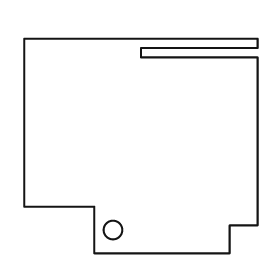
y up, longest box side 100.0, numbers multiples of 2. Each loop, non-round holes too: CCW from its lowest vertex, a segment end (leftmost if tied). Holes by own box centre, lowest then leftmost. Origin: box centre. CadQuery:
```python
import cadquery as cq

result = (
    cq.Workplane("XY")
    .moveTo(-20.0, -46.0)
    .lineTo(38.0, -46.0)
    .lineTo(38.0, -34.0)
    .lineTo(50.0, -34.0)
    .lineTo(50.0, 38.0)
    .lineTo(0.0, 38.0)
    .lineTo(0.0, 42.0)
    .lineTo(50.0, 42.0)
    .lineTo(50.0, 46.0)
    .lineTo(-50.0, 46.0)
    .lineTo(-50.0, -26.0)
    .lineTo(-20.0, -26.0)
    .close()
    .moveTo(-12.0, -36.0)
    .circle(4.0)
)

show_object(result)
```